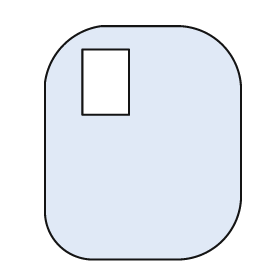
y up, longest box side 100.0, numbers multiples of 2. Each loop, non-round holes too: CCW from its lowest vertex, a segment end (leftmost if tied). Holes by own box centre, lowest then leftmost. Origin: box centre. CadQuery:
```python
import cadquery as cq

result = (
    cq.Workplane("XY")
    .moveTo(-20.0, -50.0)
    .lineTo(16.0, -50.0)
    .threePointArc((34.0, -42.0), (42.0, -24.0))
    .lineTo(42.0, 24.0)
    .threePointArc((34.0, 42.0), (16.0, 50.0))
    .lineTo(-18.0, 50.0)
    .threePointArc((-34.0, 42.0), (-42.0, 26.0))
    .lineTo(-42.0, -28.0)
    .threePointArc((-36.0, -44.0), (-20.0, -50.0))
    .close()
    .moveTo(-26.0, 12.0)
    .lineTo(-6.0, 12.0)
    .lineTo(-6.0, 40.0)
    .lineTo(-26.0, 40.0)
    .close()
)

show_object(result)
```